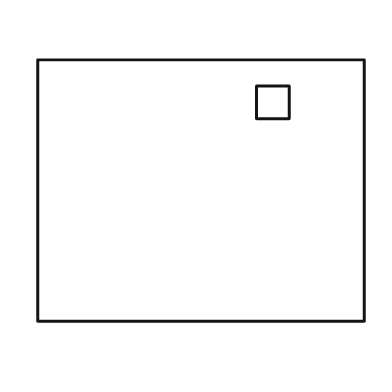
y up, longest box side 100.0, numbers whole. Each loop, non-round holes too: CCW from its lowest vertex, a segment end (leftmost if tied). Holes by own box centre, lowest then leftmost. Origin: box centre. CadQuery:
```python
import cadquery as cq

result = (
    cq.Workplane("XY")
    .moveTo(-50.0, -40.0)
    .lineTo(50.0, -40.0)
    .lineTo(50.0, 40.0)
    .lineTo(-50.0, 40.0)
    .close()
    .moveTo(17.0, 22.0)
    .lineTo(27.0, 22.0)
    .lineTo(27.0, 32.0)
    .lineTo(17.0, 32.0)
    .close()
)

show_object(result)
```